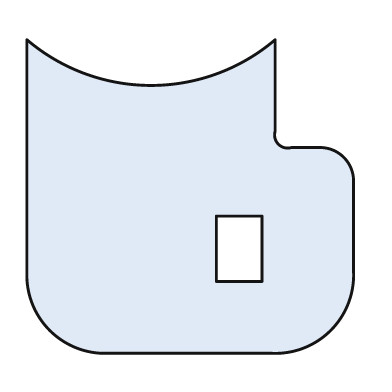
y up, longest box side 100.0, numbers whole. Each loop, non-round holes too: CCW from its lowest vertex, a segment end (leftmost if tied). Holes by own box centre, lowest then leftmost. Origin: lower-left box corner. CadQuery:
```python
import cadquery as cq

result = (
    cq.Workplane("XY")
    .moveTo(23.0, 0.0)
    .lineTo(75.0, 0.0)
    .threePointArc((93.0, 7.0), (100.0, 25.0))
    .lineTo(100.0, 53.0)
    .threePointArc((97.0, 60.0), (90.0, 63.0))
    .lineTo(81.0, 63.0)
    .threePointArc((77.0, 64.0), (76.0, 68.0))
    .lineTo(76.0, 96.0)
    .threePointArc((38.0, 82.0), (0.0, 96.0))
    .lineTo(0.0, 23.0)
    .threePointArc((7.0, 7.0), (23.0, 0.0))
    .close()
    .moveTo(58.0, 22.0)
    .lineTo(72.0, 22.0)
    .lineTo(72.0, 42.0)
    .lineTo(58.0, 42.0)
    .close()
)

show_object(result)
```